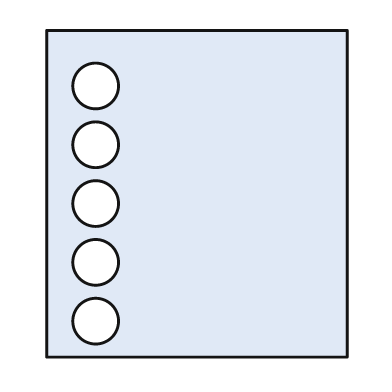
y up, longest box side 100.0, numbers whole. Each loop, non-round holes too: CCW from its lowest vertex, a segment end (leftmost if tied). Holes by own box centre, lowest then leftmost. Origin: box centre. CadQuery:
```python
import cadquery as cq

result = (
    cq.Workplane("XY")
    .moveTo(-46.0, -50.0)
    .lineTo(46.0, -50.0)
    .lineTo(46.0, 50.0)
    .lineTo(-46.0, 50.0)
    .close()
    .moveTo(-31.0, -39.0)
    .circle(7.0)
    .moveTo(-31.0, -21.0)
    .circle(7.0)
    .moveTo(-31.0, -3.0)
    .circle(7.0)
    .moveTo(-31.0, 15.0)
    .circle(7.0)
    .moveTo(-31.0, 33.0)
    .circle(7.0)
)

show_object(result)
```